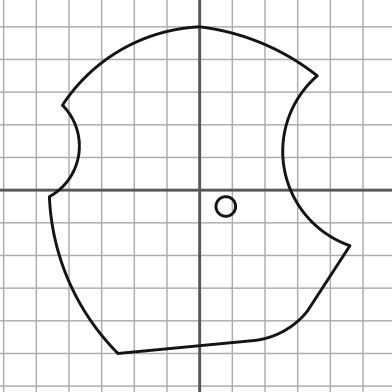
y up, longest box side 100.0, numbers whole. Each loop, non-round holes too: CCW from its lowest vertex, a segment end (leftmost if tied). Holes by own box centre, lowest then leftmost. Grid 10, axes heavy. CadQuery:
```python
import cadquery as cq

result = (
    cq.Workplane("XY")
    .moveTo(-25.0, -50.0)
    .lineTo(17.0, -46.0)
    .threePointArc((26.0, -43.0), (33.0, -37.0))
    .lineTo(46.0, -17.0)
    .threePointArc((26.0, 6.0), (36.0, 35.0))
    .threePointArc((19.0, 45.0), (0.0, 50.0))
    .threePointArc((-24.0, 43.0), (-42.0, 26.0))
    .threePointArc((-37.0, 11.0), (-46.0, -2.0))
    .threePointArc((-40.0, -28.0), (-25.0, -50.0))
    .close()
    .moveTo(8.0, -5.0)
    .circle(3.0)
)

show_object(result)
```